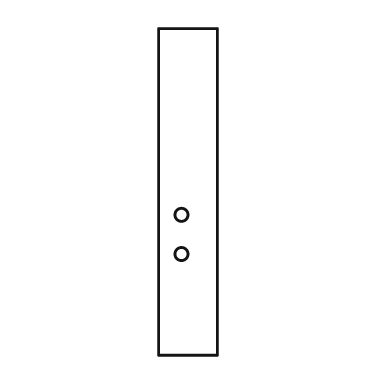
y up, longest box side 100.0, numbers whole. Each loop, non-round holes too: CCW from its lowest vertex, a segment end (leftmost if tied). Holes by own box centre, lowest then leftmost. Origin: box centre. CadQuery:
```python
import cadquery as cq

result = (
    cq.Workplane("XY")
    .moveTo(-9.0, -50.0)
    .lineTo(9.0, -50.0)
    .lineTo(9.0, 50.0)
    .lineTo(-9.0, 50.0)
    .close()
    .moveTo(-2.0, -19.0)
    .circle(2.0)
    .moveTo(-2.0, -7.0)
    .circle(2.0)
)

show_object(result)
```